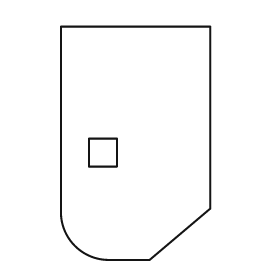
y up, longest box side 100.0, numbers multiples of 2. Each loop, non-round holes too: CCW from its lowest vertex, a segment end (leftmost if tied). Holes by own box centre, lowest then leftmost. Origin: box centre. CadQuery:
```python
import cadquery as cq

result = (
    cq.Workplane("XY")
    .moveTo(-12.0, -50.0)
    .lineTo(6.0, -50.0)
    .lineTo(32.0, -28.0)
    .lineTo(32.0, 50.0)
    .lineTo(-32.0, 50.0)
    .lineTo(-32.0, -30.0)
    .threePointArc((-26.0, -44.0), (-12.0, -50.0))
    .close()
    .moveTo(-20.0, -10.0)
    .lineTo(-8.0, -10.0)
    .lineTo(-8.0, 2.0)
    .lineTo(-20.0, 2.0)
    .close()
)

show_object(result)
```